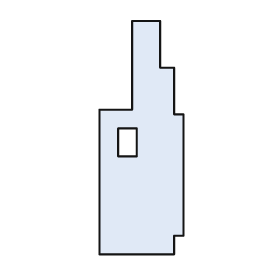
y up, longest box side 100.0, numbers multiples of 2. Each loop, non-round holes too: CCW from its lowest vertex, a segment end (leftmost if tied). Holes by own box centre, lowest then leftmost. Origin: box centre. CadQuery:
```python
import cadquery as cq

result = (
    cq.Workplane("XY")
    .moveTo(-18.0, -50.0)
    .lineTo(14.0, -50.0)
    .lineTo(14.0, -42.0)
    .lineTo(18.0, -42.0)
    .lineTo(18.0, 10.0)
    .lineTo(14.0, 10.0)
    .lineTo(14.0, 30.0)
    .lineTo(8.0, 30.0)
    .lineTo(8.0, 50.0)
    .lineTo(-4.0, 50.0)
    .lineTo(-4.0, 12.0)
    .lineTo(-18.0, 12.0)
    .close()
    .moveTo(-10.0, -8.0)
    .lineTo(-2.0, -8.0)
    .lineTo(-2.0, 4.0)
    .lineTo(-10.0, 4.0)
    .close()
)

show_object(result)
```